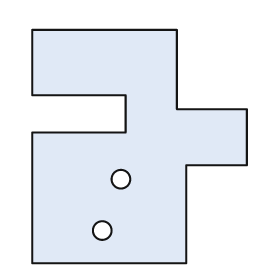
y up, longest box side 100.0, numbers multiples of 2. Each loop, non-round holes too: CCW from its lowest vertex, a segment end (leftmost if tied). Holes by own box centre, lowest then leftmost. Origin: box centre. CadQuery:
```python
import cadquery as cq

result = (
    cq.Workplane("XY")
    .moveTo(-46.0, -50.0)
    .lineTo(20.0, -50.0)
    .lineTo(20.0, -8.0)
    .lineTo(46.0, -8.0)
    .lineTo(46.0, 16.0)
    .lineTo(16.0, 16.0)
    .lineTo(16.0, 50.0)
    .lineTo(-46.0, 50.0)
    .lineTo(-46.0, 22.0)
    .lineTo(-6.0, 22.0)
    .lineTo(-6.0, 6.0)
    .lineTo(-46.0, 6.0)
    .close()
    .moveTo(-16.0, -36.0)
    .circle(4.0)
    .moveTo(-8.0, -14.0)
    .circle(4.0)
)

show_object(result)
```